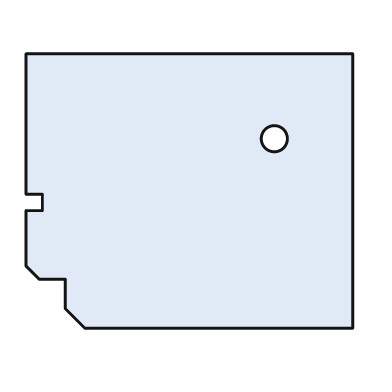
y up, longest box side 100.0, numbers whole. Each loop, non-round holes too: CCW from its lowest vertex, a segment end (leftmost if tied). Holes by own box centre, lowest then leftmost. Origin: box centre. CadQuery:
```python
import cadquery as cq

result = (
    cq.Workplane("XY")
    .moveTo(-32.0, -42.0)
    .lineTo(50.0, -42.0)
    .lineTo(50.0, 42.0)
    .lineTo(-50.0, 42.0)
    .lineTo(-50.0, -1.0)
    .lineTo(-45.0, -1.0)
    .lineTo(-45.0, -6.0)
    .lineTo(-50.0, -6.0)
    .lineTo(-50.0, -23.0)
    .lineTo(-46.0, -27.0)
    .lineTo(-38.0, -27.0)
    .lineTo(-38.0, -36.0)
    .close()
    .moveTo(26.0, 16.0)
    .circle(4.0)
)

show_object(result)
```